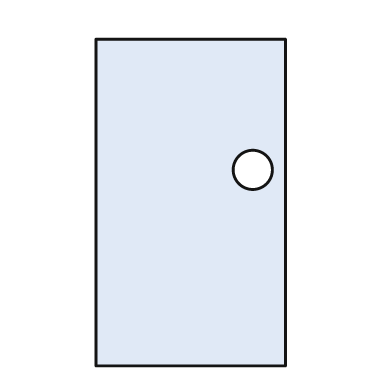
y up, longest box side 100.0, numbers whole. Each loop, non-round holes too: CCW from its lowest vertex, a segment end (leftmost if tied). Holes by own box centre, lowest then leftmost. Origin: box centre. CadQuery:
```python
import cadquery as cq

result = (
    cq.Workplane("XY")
    .moveTo(-29.0, -50.0)
    .lineTo(29.0, -50.0)
    .lineTo(29.0, 50.0)
    .lineTo(-29.0, 50.0)
    .close()
    .moveTo(19.0, 10.0)
    .circle(6.0)
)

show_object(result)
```